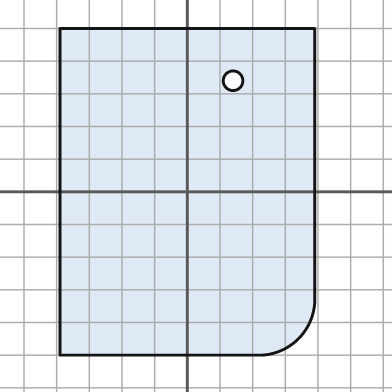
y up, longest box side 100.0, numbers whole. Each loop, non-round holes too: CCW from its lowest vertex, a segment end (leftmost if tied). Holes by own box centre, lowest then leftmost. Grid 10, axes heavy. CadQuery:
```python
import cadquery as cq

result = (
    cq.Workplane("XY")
    .moveTo(-39.0, -50.0)
    .lineTo(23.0, -50.0)
    .threePointArc((34.0, -45.0), (39.0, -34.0))
    .lineTo(39.0, 50.0)
    .lineTo(-39.0, 50.0)
    .close()
    .moveTo(14.0, 34.0)
    .circle(3.0)
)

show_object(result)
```